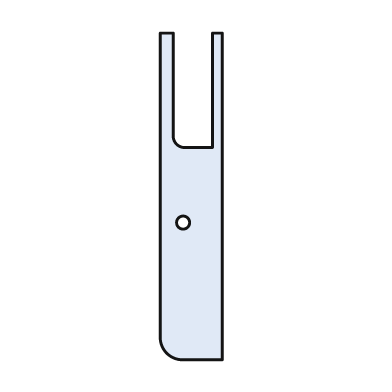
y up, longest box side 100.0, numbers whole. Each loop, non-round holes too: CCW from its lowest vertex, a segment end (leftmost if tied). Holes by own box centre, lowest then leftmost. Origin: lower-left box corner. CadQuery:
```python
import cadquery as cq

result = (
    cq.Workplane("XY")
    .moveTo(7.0, 0.0)
    .lineTo(19.0, 0.0)
    .lineTo(19.0, 100.0)
    .lineTo(16.0, 100.0)
    .lineTo(16.0, 65.0)
    .lineTo(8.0, 65.0)
    .threePointArc((5.0, 66.0), (4.0, 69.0))
    .lineTo(4.0, 100.0)
    .lineTo(0.0, 100.0)
    .lineTo(0.0, 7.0)
    .threePointArc((2.0, 2.0), (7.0, 0.0))
    .close()
    .moveTo(7.0, 42.0)
    .circle(2.0)
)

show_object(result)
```